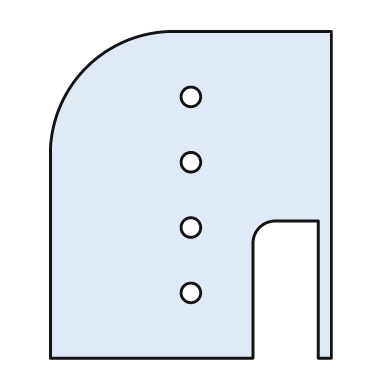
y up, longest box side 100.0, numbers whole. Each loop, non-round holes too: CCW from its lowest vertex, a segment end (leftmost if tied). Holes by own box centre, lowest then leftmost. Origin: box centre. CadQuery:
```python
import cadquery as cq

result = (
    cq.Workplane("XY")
    .moveTo(-43.0, -50.0)
    .lineTo(19.0, -50.0)
    .lineTo(19.0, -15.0)
    .threePointArc((21.0, -10.0), (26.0, -8.0))
    .lineTo(39.0, -8.0)
    .lineTo(39.0, -50.0)
    .lineTo(43.0, -50.0)
    .lineTo(43.0, 50.0)
    .lineTo(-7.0, 50.0)
    .threePointArc((-32.0, 39.0), (-43.0, 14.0))
    .close()
    .moveTo(0.0, -30.0)
    .circle(3.0)
    .moveTo(0.0, -10.0)
    .circle(3.0)
    .moveTo(0.0, 10.0)
    .circle(3.0)
    .moveTo(0.0, 30.0)
    .circle(3.0)
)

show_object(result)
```